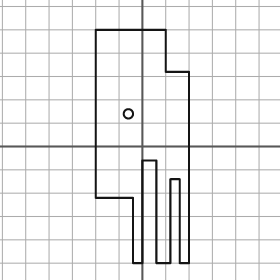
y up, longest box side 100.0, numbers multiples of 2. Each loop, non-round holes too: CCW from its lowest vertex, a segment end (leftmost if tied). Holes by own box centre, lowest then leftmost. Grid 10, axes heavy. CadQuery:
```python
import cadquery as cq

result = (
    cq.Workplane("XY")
    .moveTo(-4.0, -50.0)
    .lineTo(0.0, -50.0)
    .lineTo(0.0, -6.0)
    .lineTo(6.0, -6.0)
    .lineTo(6.0, -50.0)
    .lineTo(12.0, -50.0)
    .lineTo(12.0, -14.0)
    .lineTo(16.0, -14.0)
    .lineTo(16.0, -50.0)
    .lineTo(20.0, -50.0)
    .lineTo(20.0, 32.0)
    .lineTo(10.0, 32.0)
    .lineTo(10.0, 50.0)
    .lineTo(-20.0, 50.0)
    .lineTo(-20.0, -22.0)
    .lineTo(-4.0, -22.0)
    .close()
    .moveTo(-6.0, 14.0)
    .circle(2.0)
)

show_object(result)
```